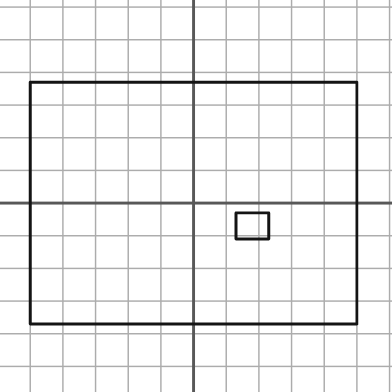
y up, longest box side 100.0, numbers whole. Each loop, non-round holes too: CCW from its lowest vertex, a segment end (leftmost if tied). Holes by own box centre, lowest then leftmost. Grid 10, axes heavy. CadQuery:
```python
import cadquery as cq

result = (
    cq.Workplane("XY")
    .moveTo(-50.0, -37.0)
    .lineTo(50.0, -37.0)
    .lineTo(50.0, 37.0)
    .lineTo(-50.0, 37.0)
    .close()
    .moveTo(13.0, -11.0)
    .lineTo(23.0, -11.0)
    .lineTo(23.0, -3.0)
    .lineTo(13.0, -3.0)
    .close()
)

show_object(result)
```